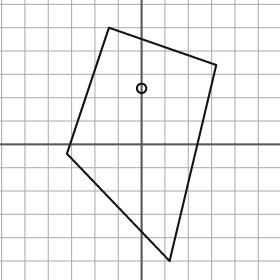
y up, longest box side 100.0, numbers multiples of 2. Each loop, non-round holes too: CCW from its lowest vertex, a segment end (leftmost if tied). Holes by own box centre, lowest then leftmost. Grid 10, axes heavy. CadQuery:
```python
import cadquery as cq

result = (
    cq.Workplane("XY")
    .moveTo(12.0, -50.0)
    .lineTo(32.0, 34.0)
    .lineTo(-14.0, 50.0)
    .lineTo(-32.0, -4.0)
    .close()
    .moveTo(0.0, 24.0)
    .circle(2.0)
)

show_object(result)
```